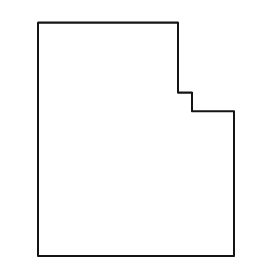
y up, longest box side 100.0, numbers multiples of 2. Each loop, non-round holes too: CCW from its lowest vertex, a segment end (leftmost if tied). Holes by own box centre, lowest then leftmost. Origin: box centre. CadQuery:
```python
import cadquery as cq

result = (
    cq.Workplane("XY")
    .moveTo(-42.0, -50.0)
    .lineTo(42.0, -50.0)
    .lineTo(42.0, 12.0)
    .lineTo(24.0, 12.0)
    .lineTo(24.0, 20.0)
    .lineTo(18.0, 20.0)
    .lineTo(18.0, 50.0)
    .lineTo(-42.0, 50.0)
    .close()
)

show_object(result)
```